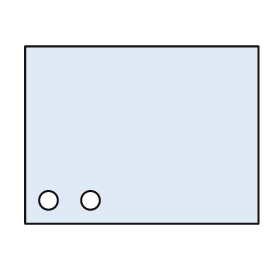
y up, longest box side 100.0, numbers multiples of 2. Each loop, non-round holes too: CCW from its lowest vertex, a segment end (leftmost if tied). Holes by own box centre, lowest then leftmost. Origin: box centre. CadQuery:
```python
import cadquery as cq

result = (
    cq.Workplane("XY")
    .moveTo(-50.0, -38.0)
    .lineTo(50.0, -38.0)
    .lineTo(50.0, 38.0)
    .lineTo(-50.0, 38.0)
    .close()
    .moveTo(-40.0, -28.0)
    .circle(4.0)
    .moveTo(-22.0, -28.0)
    .circle(4.0)
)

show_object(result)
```